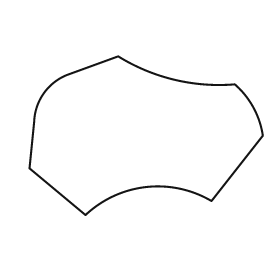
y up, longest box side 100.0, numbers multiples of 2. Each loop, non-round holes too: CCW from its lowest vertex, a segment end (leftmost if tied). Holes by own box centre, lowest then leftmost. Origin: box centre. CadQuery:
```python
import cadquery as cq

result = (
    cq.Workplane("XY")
    .moveTo(-26.0, -34.0)
    .threePointArc((0.0, -22.0), (28.0, -28.0))
    .lineTo(50.0, 0.0)
    .threePointArc((46.0, 12.0), (38.0, 22.0))
    .threePointArc((12.0, 24.0), (-12.0, 34.0))
    .lineTo(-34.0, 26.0)
    .threePointArc((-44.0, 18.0), (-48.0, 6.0))
    .lineTo(-50.0, -14.0)
    .close()
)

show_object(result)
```